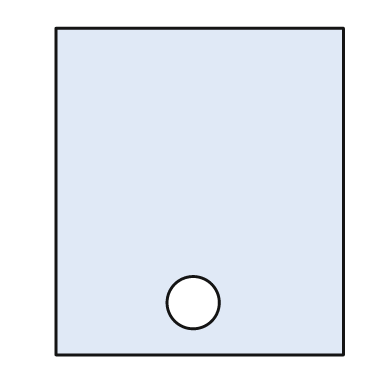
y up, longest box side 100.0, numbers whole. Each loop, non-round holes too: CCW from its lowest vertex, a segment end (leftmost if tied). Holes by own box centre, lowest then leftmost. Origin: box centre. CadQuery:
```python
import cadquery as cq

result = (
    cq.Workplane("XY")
    .moveTo(-44.0, -50.0)
    .lineTo(44.0, -50.0)
    .lineTo(44.0, 50.0)
    .lineTo(-44.0, 50.0)
    .close()
    .moveTo(-2.0, -34.0)
    .circle(8.0)
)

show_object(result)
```